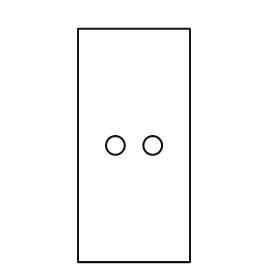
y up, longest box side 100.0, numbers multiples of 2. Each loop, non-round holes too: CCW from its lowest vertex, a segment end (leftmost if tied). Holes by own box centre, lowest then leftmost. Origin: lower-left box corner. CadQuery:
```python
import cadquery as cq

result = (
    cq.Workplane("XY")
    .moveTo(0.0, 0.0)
    .lineTo(48.0, 0.0)
    .lineTo(48.0, 100.0)
    .lineTo(0.0, 100.0)
    .close()
    .moveTo(16.0, 50.0)
    .circle(4.0)
    .moveTo(32.0, 50.0)
    .circle(4.0)
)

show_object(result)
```